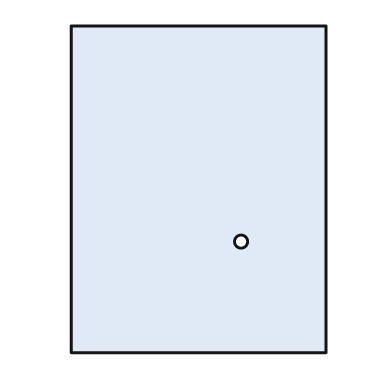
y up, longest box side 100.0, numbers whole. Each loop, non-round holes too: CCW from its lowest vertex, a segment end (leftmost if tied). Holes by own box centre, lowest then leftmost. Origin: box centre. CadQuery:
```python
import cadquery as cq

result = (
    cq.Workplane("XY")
    .moveTo(-39.0, -50.0)
    .lineTo(39.0, -50.0)
    .lineTo(39.0, 50.0)
    .lineTo(-39.0, 50.0)
    .close()
    .moveTo(13.0, -16.0)
    .circle(2.0)
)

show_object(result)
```